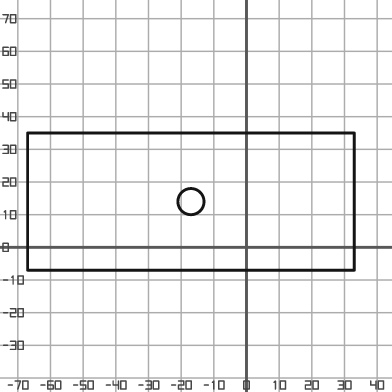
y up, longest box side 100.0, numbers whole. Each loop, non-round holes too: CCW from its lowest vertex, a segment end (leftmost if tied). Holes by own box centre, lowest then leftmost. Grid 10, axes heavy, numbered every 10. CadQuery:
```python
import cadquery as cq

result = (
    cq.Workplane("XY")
    .moveTo(-67.0, -7.0)
    .lineTo(33.0, -7.0)
    .lineTo(33.0, 35.0)
    .lineTo(-67.0, 35.0)
    .close()
    .moveTo(-17.0, 14.0)
    .circle(4.0)
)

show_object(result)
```